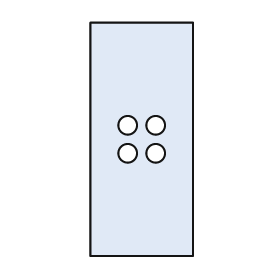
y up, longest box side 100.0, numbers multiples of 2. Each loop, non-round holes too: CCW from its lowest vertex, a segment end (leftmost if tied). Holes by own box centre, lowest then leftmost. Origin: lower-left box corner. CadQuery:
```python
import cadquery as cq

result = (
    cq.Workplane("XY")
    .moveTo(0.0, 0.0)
    .lineTo(44.0, 0.0)
    .lineTo(44.0, 100.0)
    .lineTo(0.0, 100.0)
    .close()
    .moveTo(16.0, 44.0)
    .circle(4.0)
    .moveTo(28.0, 44.0)
    .circle(4.0)
    .moveTo(16.0, 56.0)
    .circle(4.0)
    .moveTo(28.0, 56.0)
    .circle(4.0)
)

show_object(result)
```